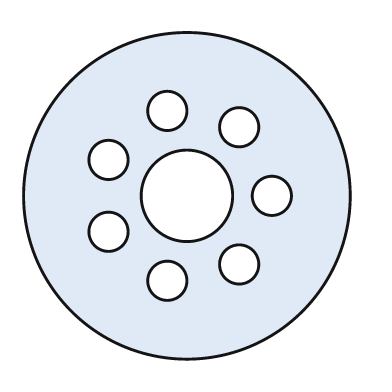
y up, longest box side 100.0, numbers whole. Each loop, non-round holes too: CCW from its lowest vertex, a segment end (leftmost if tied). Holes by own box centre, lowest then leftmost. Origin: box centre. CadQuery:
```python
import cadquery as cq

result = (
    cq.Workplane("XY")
    .moveTo(0.0, 0.0)
    .circle(50.0)
    .moveTo(-6.0, -26.0)
    .circle(6.0)
    .moveTo(16.0, -21.0)
    .circle(6.0)
    .moveTo(-24.0, -11.0)
    .circle(6.0)
    .moveTo(0.0, 0.0)
    .circle(14.0)
    .moveTo(26.0, 0.0)
    .circle(6.0)
    .moveTo(-24.0, 11.0)
    .circle(6.0)
    .moveTo(16.0, 21.0)
    .circle(6.0)
    .moveTo(-6.0, 26.0)
    .circle(6.0)
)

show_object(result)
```